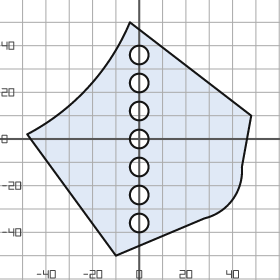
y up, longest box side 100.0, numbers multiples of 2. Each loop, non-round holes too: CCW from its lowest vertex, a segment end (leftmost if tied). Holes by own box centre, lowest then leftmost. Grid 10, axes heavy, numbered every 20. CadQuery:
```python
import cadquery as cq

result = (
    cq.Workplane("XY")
    .moveTo(-10.0, -50.0)
    .lineTo(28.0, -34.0)
    .threePointArc((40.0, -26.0), (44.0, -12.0))
    .lineTo(48.0, 10.0)
    .lineTo(-4.0, 50.0)
    .threePointArc((-22.0, 22.0), (-48.0, 2.0))
    .close()
    .moveTo(0.0, -36.0)
    .circle(4.0)
    .moveTo(0.0, -24.0)
    .circle(4.0)
    .moveTo(0.0, -12.0)
    .circle(4.0)
    .moveTo(0.0, 0.0)
    .circle(4.0)
    .moveTo(0.0, 12.0)
    .circle(4.0)
    .moveTo(0.0, 24.0)
    .circle(4.0)
    .moveTo(0.0, 36.0)
    .circle(4.0)
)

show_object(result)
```